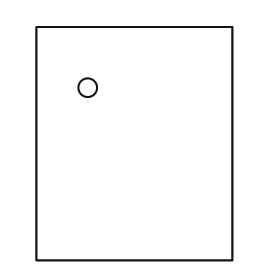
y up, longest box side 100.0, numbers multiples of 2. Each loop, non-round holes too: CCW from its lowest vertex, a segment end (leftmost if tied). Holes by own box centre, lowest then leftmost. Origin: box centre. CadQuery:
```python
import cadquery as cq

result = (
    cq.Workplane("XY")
    .moveTo(-42.0, -50.0)
    .lineTo(42.0, -50.0)
    .lineTo(42.0, 50.0)
    .lineTo(-42.0, 50.0)
    .close()
    .moveTo(-20.0, 24.0)
    .circle(4.0)
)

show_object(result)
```